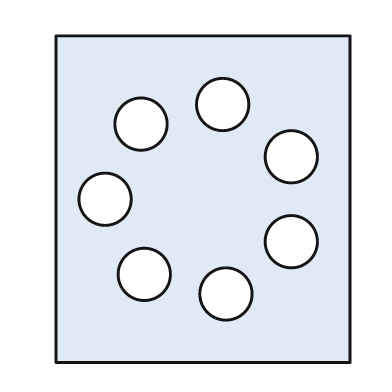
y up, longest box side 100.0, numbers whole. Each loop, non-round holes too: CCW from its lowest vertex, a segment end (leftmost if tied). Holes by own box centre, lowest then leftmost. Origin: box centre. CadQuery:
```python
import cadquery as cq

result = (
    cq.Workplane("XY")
    .moveTo(-45.0, -50.0)
    .lineTo(45.0, -50.0)
    .lineTo(45.0, 50.0)
    .lineTo(-45.0, 50.0)
    .close()
    .moveTo(7.0, -29.0)
    .circle(8.0)
    .moveTo(-18.0, -23.0)
    .circle(8.0)
    .moveTo(27.0, -13.0)
    .circle(8.0)
    .moveTo(-30.0, 0.0)
    .circle(8.0)
    .moveTo(27.0, 13.0)
    .circle(8.0)
    .moveTo(-19.0, 23.0)
    .circle(8.0)
    .moveTo(6.0, 29.0)
    .circle(8.0)
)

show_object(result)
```